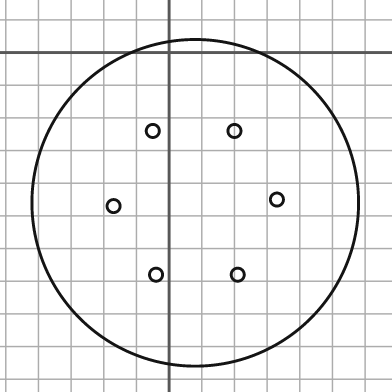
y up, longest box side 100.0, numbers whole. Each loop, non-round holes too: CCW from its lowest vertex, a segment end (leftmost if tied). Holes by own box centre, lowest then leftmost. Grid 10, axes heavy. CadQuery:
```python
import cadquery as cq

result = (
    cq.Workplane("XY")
    .moveTo(8.0, -46.0)
    .circle(50.0)
    .moveTo(-4.0, -68.0)
    .circle(2.0)
    .moveTo(21.0, -68.0)
    .circle(2.0)
    .moveTo(-17.0, -47.0)
    .circle(2.0)
    .moveTo(33.0, -45.0)
    .circle(2.0)
    .moveTo(-5.0, -24.0)
    .circle(2.0)
    .moveTo(20.0, -24.0)
    .circle(2.0)
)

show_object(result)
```